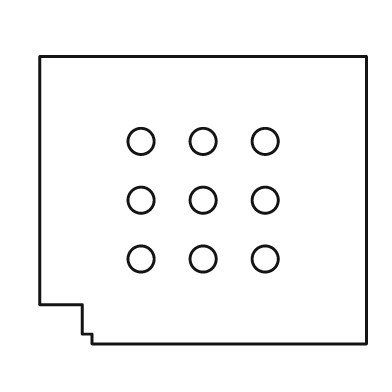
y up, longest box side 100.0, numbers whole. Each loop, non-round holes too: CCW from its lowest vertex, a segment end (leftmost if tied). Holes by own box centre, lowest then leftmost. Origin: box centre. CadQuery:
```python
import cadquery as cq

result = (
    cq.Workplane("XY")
    .moveTo(-34.0, -44.0)
    .lineTo(50.0, -44.0)
    .lineTo(50.0, 44.0)
    .lineTo(-50.0, 44.0)
    .lineTo(-50.0, -32.0)
    .lineTo(-37.0, -32.0)
    .lineTo(-37.0, -41.0)
    .lineTo(-34.0, -41.0)
    .close()
    .moveTo(-19.0, -18.0)
    .circle(4.0)
    .moveTo(0.0, -18.0)
    .circle(4.0)
    .moveTo(19.0, -18.0)
    .circle(4.0)
    .moveTo(-19.0, 0.0)
    .circle(4.0)
    .moveTo(0.0, 0.0)
    .circle(4.0)
    .moveTo(19.0, 0.0)
    .circle(4.0)
    .moveTo(-19.0, 18.0)
    .circle(4.0)
    .moveTo(0.0, 18.0)
    .circle(4.0)
    .moveTo(19.0, 18.0)
    .circle(4.0)
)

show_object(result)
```